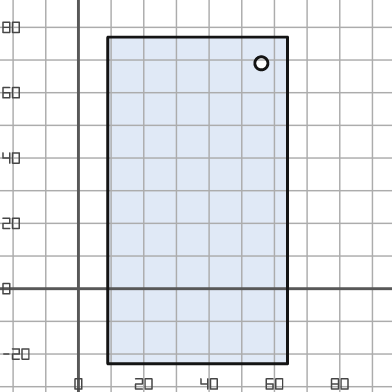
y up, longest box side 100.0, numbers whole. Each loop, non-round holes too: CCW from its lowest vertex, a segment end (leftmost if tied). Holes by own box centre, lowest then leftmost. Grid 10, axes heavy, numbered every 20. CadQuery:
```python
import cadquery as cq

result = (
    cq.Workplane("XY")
    .moveTo(9.0, -23.0)
    .lineTo(64.0, -23.0)
    .lineTo(64.0, 77.0)
    .lineTo(9.0, 77.0)
    .close()
    .moveTo(56.0, 69.0)
    .circle(2.0)
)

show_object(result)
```